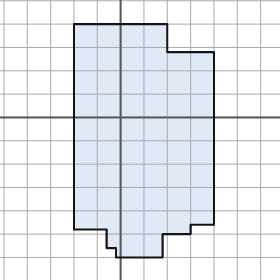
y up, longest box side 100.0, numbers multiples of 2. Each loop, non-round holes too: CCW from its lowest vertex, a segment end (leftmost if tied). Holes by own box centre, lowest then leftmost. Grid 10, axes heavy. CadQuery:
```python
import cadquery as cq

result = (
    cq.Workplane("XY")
    .moveTo(-2.0, -60.0)
    .lineTo(18.0, -60.0)
    .lineTo(18.0, -50.0)
    .lineTo(30.0, -50.0)
    .lineTo(30.0, -46.0)
    .lineTo(40.0, -46.0)
    .lineTo(40.0, 28.0)
    .lineTo(20.0, 28.0)
    .lineTo(20.0, 40.0)
    .lineTo(-20.0, 40.0)
    .lineTo(-20.0, -48.0)
    .lineTo(-6.0, -48.0)
    .lineTo(-6.0, -56.0)
    .lineTo(-2.0, -56.0)
    .close()
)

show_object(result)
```